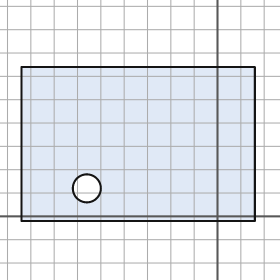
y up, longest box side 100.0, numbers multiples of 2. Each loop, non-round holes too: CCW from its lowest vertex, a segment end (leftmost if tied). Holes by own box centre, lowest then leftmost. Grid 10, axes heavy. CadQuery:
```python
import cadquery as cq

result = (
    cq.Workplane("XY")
    .moveTo(-84.0, -2.0)
    .lineTo(16.0, -2.0)
    .lineTo(16.0, 64.0)
    .lineTo(-84.0, 64.0)
    .close()
    .moveTo(-56.0, 12.0)
    .circle(6.0)
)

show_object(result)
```